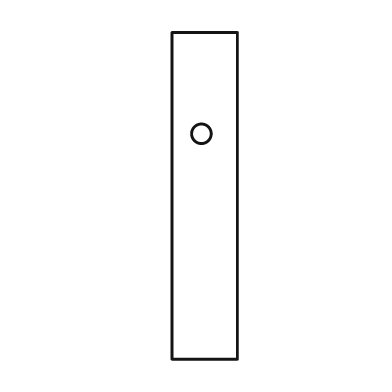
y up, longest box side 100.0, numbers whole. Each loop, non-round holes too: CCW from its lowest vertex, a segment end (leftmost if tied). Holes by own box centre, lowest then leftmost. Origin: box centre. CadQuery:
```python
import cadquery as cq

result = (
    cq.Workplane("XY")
    .moveTo(-10.0, -50.0)
    .lineTo(10.0, -50.0)
    .lineTo(10.0, 50.0)
    .lineTo(-10.0, 50.0)
    .close()
    .moveTo(-1.0, 19.0)
    .circle(3.0)
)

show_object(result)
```